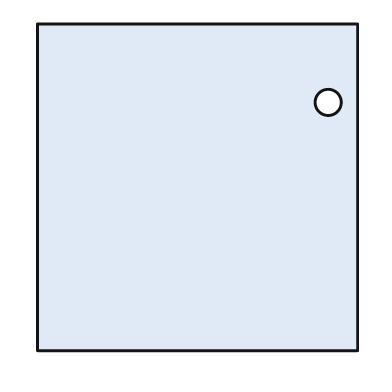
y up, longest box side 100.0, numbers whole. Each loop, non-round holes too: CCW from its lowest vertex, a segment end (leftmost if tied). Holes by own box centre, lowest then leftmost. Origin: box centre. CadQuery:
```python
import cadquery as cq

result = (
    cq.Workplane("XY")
    .moveTo(-49.0, -50.0)
    .lineTo(49.0, -50.0)
    .lineTo(49.0, 50.0)
    .lineTo(-49.0, 50.0)
    .close()
    .moveTo(40.0, 26.0)
    .circle(4.0)
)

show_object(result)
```